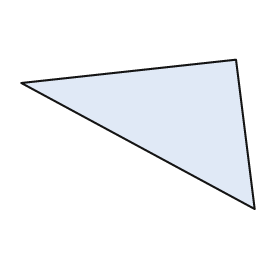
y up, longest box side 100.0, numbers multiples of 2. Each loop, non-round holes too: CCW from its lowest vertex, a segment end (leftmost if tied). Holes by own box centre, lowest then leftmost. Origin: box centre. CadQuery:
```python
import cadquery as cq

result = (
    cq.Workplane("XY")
    .moveTo(50.0, -32.0)
    .lineTo(42.0, 32.0)
    .lineTo(-50.0, 22.0)
    .close()
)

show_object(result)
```